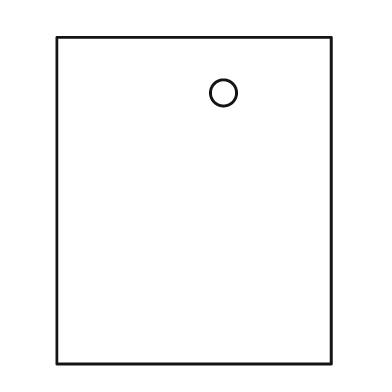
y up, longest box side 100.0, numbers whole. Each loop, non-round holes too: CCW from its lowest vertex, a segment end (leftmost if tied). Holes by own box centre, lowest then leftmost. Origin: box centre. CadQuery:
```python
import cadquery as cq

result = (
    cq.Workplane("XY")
    .moveTo(-42.0, -50.0)
    .lineTo(42.0, -50.0)
    .lineTo(42.0, 50.0)
    .lineTo(-42.0, 50.0)
    .close()
    .moveTo(9.0, 33.0)
    .circle(4.0)
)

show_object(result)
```